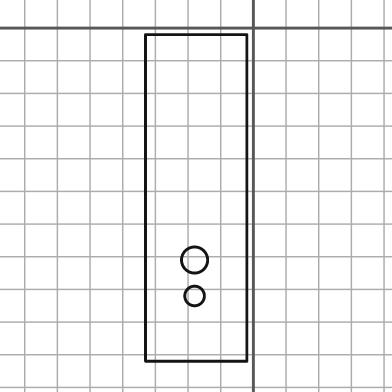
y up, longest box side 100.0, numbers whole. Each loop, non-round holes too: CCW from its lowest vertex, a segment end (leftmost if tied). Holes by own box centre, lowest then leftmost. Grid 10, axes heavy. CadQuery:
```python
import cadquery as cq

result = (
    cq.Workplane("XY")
    .moveTo(-33.0, -102.0)
    .lineTo(-2.0, -102.0)
    .lineTo(-2.0, -2.0)
    .lineTo(-33.0, -2.0)
    .close()
    .moveTo(-18.0, -82.0)
    .circle(3.0)
    .moveTo(-18.0, -71.0)
    .circle(4.0)
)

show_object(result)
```